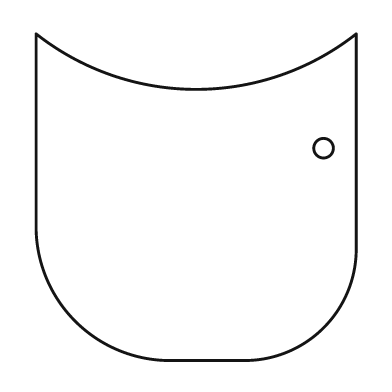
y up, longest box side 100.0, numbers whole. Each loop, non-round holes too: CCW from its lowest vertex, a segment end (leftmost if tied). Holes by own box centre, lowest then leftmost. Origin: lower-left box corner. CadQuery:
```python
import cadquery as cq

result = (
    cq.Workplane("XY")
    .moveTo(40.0, 0.0)
    .lineTo(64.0, 0.0)
    .threePointArc((88.0, 10.0), (98.0, 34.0))
    .lineTo(98.0, 100.0)
    .threePointArc((49.0, 83.0), (0.0, 100.0))
    .lineTo(0.0, 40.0)
    .threePointArc((12.0, 12.0), (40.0, 0.0))
    .close()
    .moveTo(88.0, 65.0)
    .circle(3.0)
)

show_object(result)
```